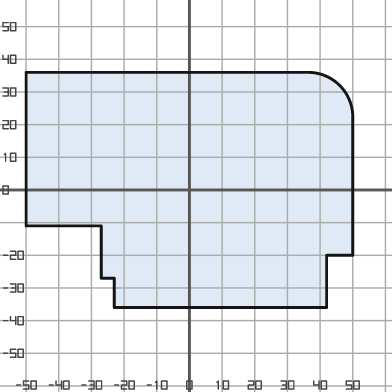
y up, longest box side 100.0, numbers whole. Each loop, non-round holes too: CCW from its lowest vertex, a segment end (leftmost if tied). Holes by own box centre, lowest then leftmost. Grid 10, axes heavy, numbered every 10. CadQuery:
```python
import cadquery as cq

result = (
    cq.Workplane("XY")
    .moveTo(-23.0, -36.0)
    .lineTo(42.0, -36.0)
    .lineTo(42.0, -20.0)
    .lineTo(50.0, -20.0)
    .lineTo(50.0, 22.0)
    .threePointArc((46.0, 32.0), (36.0, 36.0))
    .lineTo(-50.0, 36.0)
    .lineTo(-50.0, -11.0)
    .lineTo(-27.0, -11.0)
    .lineTo(-27.0, -27.0)
    .lineTo(-23.0, -27.0)
    .close()
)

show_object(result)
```